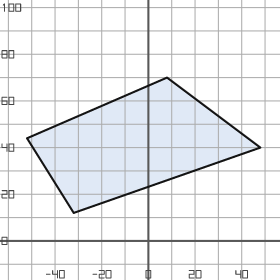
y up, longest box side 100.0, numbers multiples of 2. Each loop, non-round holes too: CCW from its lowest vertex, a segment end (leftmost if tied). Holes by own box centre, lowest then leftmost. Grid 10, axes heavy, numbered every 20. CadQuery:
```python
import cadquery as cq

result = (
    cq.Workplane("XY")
    .moveTo(-32.0, 12.0)
    .lineTo(48.0, 40.0)
    .lineTo(8.0, 70.0)
    .lineTo(-52.0, 44.0)
    .close()
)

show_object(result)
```